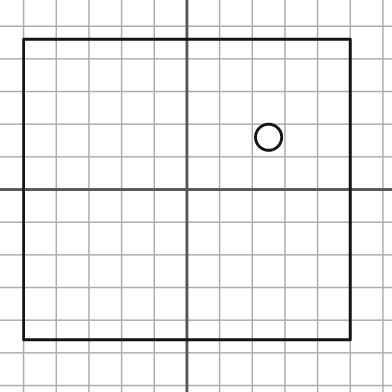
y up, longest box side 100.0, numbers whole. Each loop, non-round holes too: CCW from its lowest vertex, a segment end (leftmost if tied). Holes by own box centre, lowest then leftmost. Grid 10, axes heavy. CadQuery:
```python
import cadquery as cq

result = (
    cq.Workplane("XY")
    .moveTo(-50.0, -46.0)
    .lineTo(50.0, -46.0)
    .lineTo(50.0, 46.0)
    .lineTo(-50.0, 46.0)
    .close()
    .moveTo(25.0, 16.0)
    .circle(4.0)
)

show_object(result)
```